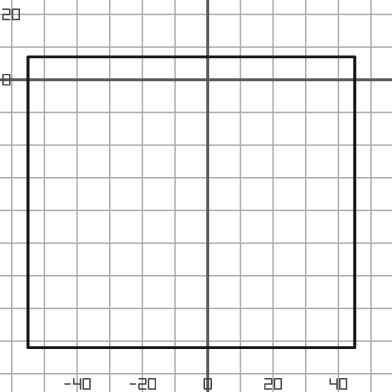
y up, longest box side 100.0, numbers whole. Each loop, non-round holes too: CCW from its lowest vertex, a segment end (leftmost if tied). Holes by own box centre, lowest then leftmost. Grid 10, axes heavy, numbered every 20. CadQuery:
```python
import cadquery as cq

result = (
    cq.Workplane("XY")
    .moveTo(-55.0, -82.0)
    .lineTo(45.0, -82.0)
    .lineTo(45.0, 7.0)
    .lineTo(-55.0, 7.0)
    .close()
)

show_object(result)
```